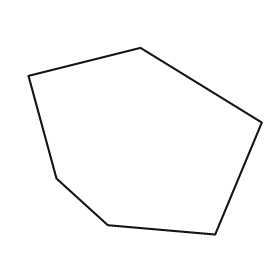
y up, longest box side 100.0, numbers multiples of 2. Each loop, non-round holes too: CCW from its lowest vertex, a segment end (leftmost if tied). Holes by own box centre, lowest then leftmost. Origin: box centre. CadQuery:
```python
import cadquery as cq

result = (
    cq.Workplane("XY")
    .moveTo(30.0, -40.0)
    .lineTo(50.0, 8.0)
    .lineTo(-2.0, 40.0)
    .lineTo(-50.0, 28.0)
    .lineTo(-38.0, -16.0)
    .lineTo(-16.0, -36.0)
    .close()
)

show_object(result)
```